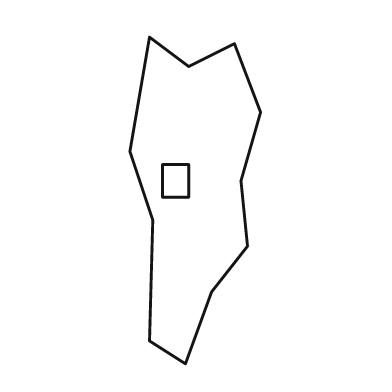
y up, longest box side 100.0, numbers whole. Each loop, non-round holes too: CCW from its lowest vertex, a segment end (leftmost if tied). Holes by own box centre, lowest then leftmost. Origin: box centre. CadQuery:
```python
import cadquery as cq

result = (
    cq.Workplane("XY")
    .moveTo(-3.0, -50.0)
    .lineTo(5.0, -28.0)
    .lineTo(16.0, -14.0)
    .lineTo(14.0, 6.0)
    .lineTo(20.0, 27.0)
    .lineTo(12.0, 48.0)
    .lineTo(-2.0, 41.0)
    .lineTo(-14.0, 50.0)
    .lineTo(-20.0, 15.0)
    .lineTo(-13.0, -6.0)
    .lineTo(-14.0, -43.0)
    .close()
    .moveTo(-10.0, 1.0)
    .lineTo(-2.0, 1.0)
    .lineTo(-2.0, 11.0)
    .lineTo(-10.0, 11.0)
    .close()
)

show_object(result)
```